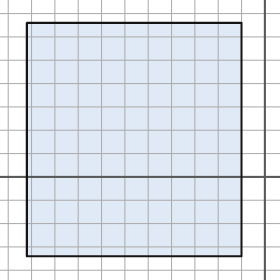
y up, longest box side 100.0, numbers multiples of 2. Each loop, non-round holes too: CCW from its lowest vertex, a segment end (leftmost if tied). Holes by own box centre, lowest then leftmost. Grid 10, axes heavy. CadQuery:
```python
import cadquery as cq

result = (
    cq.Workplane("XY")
    .moveTo(-102.0, -34.0)
    .lineTo(-10.0, -34.0)
    .lineTo(-10.0, 66.0)
    .lineTo(-102.0, 66.0)
    .close()
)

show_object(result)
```